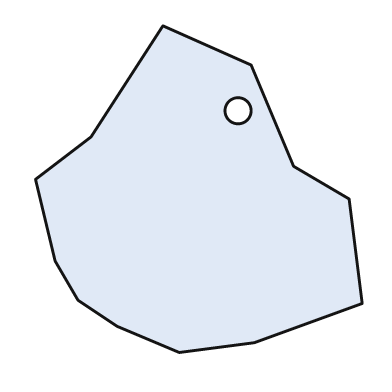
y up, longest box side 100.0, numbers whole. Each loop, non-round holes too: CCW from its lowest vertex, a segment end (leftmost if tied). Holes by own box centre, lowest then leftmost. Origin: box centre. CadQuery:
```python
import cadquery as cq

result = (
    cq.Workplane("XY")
    .moveTo(-6.0, -50.0)
    .lineTo(17.0, -47.0)
    .lineTo(50.0, -35.0)
    .lineTo(46.0, -3.0)
    .lineTo(29.0, 7.0)
    .lineTo(16.0, 38.0)
    .lineTo(-11.0, 50.0)
    .lineTo(-33.0, 16.0)
    .lineTo(-50.0, 3.0)
    .lineTo(-44.0, -22.0)
    .lineTo(-37.0, -34.0)
    .lineTo(-25.0, -42.0)
    .close()
    .moveTo(12.0, 24.0)
    .circle(4.0)
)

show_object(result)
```